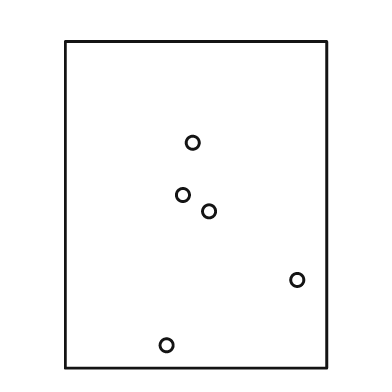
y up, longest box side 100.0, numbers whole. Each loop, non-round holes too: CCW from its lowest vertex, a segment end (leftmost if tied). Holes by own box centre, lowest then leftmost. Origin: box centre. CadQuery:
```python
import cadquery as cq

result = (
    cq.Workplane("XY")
    .moveTo(-40.0, -50.0)
    .lineTo(40.0, -50.0)
    .lineTo(40.0, 50.0)
    .lineTo(-40.0, 50.0)
    .close()
    .moveTo(-9.0, -43.0)
    .circle(2.0)
    .moveTo(31.0, -23.0)
    .circle(2.0)
    .moveTo(4.0, -2.0)
    .circle(2.0)
    .moveTo(-4.0, 3.0)
    .circle(2.0)
    .moveTo(-1.0, 19.0)
    .circle(2.0)
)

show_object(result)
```